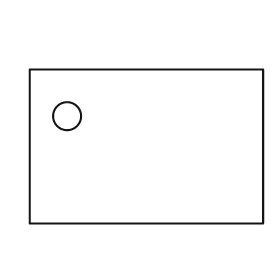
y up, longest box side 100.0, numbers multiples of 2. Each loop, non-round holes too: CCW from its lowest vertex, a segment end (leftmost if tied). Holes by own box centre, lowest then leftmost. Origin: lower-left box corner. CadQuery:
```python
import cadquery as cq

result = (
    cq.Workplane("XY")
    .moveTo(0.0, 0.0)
    .lineTo(100.0, 0.0)
    .lineTo(100.0, 66.0)
    .lineTo(0.0, 66.0)
    .close()
    .moveTo(16.0, 46.0)
    .circle(6.0)
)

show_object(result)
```